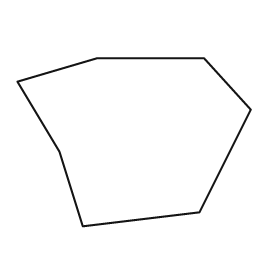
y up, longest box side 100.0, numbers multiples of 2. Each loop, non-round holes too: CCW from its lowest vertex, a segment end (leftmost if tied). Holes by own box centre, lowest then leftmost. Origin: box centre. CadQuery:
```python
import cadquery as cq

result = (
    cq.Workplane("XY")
    .moveTo(-22.0, -36.0)
    .lineTo(28.0, -30.0)
    .lineTo(50.0, 14.0)
    .lineTo(30.0, 36.0)
    .lineTo(-16.0, 36.0)
    .lineTo(-50.0, 26.0)
    .lineTo(-32.0, -4.0)
    .close()
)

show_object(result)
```